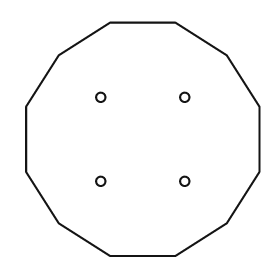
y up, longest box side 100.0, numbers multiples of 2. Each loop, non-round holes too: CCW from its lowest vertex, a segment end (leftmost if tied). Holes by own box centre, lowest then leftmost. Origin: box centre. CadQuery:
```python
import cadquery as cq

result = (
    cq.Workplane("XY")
    .moveTo(-14.0, -50.0)
    .lineTo(14.0, -50.0)
    .lineTo(36.0, -36.0)
    .lineTo(50.0, -14.0)
    .lineTo(50.0, 14.0)
    .lineTo(36.0, 36.0)
    .lineTo(14.0, 50.0)
    .lineTo(-14.0, 50.0)
    .lineTo(-36.0, 36.0)
    .lineTo(-50.0, 14.0)
    .lineTo(-50.0, -14.0)
    .lineTo(-36.0, -36.0)
    .close()
    .moveTo(-18.0, -18.0)
    .circle(2.0)
    .moveTo(18.0, -18.0)
    .circle(2.0)
    .moveTo(-18.0, 18.0)
    .circle(2.0)
    .moveTo(18.0, 18.0)
    .circle(2.0)
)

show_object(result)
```